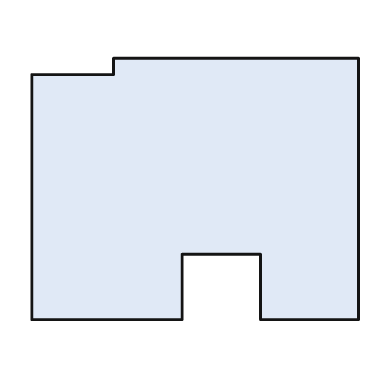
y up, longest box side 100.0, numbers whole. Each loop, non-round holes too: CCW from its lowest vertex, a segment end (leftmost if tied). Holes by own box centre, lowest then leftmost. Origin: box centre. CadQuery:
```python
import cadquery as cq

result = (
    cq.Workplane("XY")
    .moveTo(-50.0, -40.0)
    .lineTo(-4.0, -40.0)
    .lineTo(-4.0, -20.0)
    .lineTo(20.0, -20.0)
    .lineTo(20.0, -40.0)
    .lineTo(50.0, -40.0)
    .lineTo(50.0, 40.0)
    .lineTo(-25.0, 40.0)
    .lineTo(-25.0, 35.0)
    .lineTo(-50.0, 35.0)
    .close()
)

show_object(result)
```